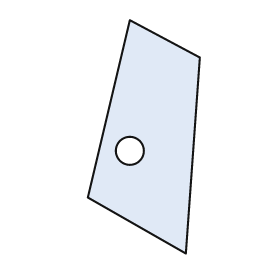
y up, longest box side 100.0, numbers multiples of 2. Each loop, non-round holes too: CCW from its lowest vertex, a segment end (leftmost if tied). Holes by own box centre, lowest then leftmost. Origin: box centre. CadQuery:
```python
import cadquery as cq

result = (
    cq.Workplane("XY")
    .moveTo(18.0, -50.0)
    .lineTo(24.0, 34.0)
    .lineTo(-6.0, 50.0)
    .lineTo(-24.0, -26.0)
    .close()
    .moveTo(-6.0, -6.0)
    .circle(6.0)
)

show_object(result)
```